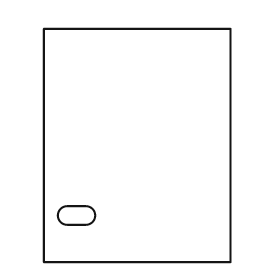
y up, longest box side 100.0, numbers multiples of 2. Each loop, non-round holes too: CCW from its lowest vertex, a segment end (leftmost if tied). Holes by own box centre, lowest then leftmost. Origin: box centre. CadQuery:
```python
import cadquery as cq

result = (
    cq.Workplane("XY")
    .moveTo(-40.0, -50.0)
    .lineTo(40.0, -50.0)
    .lineTo(40.0, 50.0)
    .lineTo(-40.0, 50.0)
    .close()
    .moveTo(-30.0, -34.0)
    .lineTo(-22.0, -34.0)
    .threePointArc((-18.0, -30.0), (-22.0, -26.0))
    .lineTo(-30.0, -26.0)
    .threePointArc((-34.0, -30.0), (-30.0, -34.0))
    .close()
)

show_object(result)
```